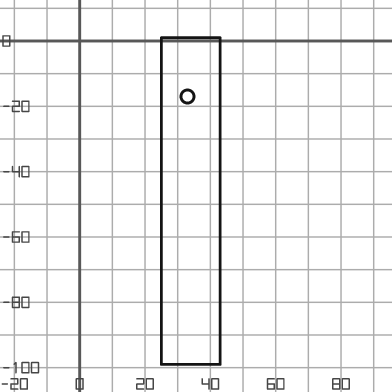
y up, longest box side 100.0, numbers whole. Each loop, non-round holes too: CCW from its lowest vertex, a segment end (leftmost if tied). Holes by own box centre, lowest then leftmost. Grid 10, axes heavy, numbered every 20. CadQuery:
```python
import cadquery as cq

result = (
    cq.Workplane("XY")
    .moveTo(25.0, -99.0)
    .lineTo(43.0, -99.0)
    .lineTo(43.0, 1.0)
    .lineTo(25.0, 1.0)
    .close()
    .moveTo(33.0, -17.0)
    .circle(2.0)
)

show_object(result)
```